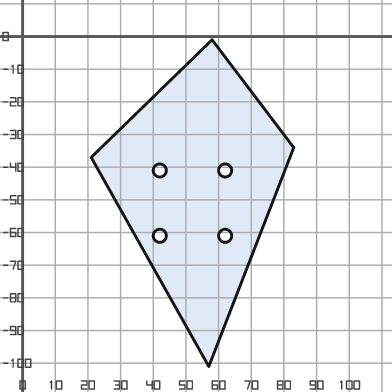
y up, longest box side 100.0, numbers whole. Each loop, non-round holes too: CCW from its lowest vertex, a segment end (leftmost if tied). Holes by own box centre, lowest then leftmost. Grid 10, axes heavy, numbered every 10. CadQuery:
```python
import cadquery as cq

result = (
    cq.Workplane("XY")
    .moveTo(57.0, -101.0)
    .lineTo(83.0, -34.0)
    .lineTo(58.0, -1.0)
    .lineTo(21.0, -37.0)
    .close()
    .moveTo(42.0, -61.0)
    .circle(2.0)
    .moveTo(62.0, -61.0)
    .circle(2.0)
    .moveTo(42.0, -41.0)
    .circle(2.0)
    .moveTo(62.0, -41.0)
    .circle(2.0)
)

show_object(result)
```